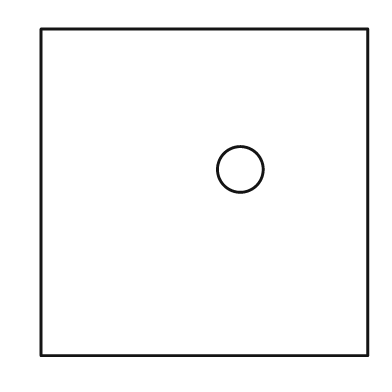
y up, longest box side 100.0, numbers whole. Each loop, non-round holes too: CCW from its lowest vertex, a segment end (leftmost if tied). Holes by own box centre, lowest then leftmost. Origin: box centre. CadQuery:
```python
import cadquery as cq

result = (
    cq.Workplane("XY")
    .moveTo(-50.0, -50.0)
    .lineTo(50.0, -50.0)
    .lineTo(50.0, 50.0)
    .lineTo(-50.0, 50.0)
    .close()
    .moveTo(11.0, 7.0)
    .circle(7.0)
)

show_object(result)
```